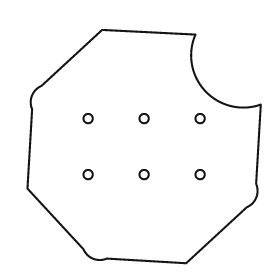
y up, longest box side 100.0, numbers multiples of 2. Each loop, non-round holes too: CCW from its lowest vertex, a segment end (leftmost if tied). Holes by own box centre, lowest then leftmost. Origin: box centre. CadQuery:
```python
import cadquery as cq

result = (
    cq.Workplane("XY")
    .moveTo(18.0, -50.0)
    .lineTo(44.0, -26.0)
    .threePointArc((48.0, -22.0), (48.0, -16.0))
    .lineTo(50.0, 18.0)
    .threePointArc((26.0, 24.0), (22.0, 48.0))
    .lineTo(-18.0, 50.0)
    .lineTo(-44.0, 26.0)
    .threePointArc((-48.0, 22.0), (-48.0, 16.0))
    .lineTo(-50.0, -18.0)
    .lineTo(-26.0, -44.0)
    .threePointArc((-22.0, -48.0), (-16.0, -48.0))
    .close()
    .moveTo(-24.0, -12.0)
    .circle(2.0)
    .moveTo(0.0, -12.0)
    .circle(2.0)
    .moveTo(24.0, -12.0)
    .circle(2.0)
    .moveTo(-24.0, 12.0)
    .circle(2.0)
    .moveTo(0.0, 12.0)
    .circle(2.0)
    .moveTo(24.0, 12.0)
    .circle(2.0)
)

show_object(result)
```